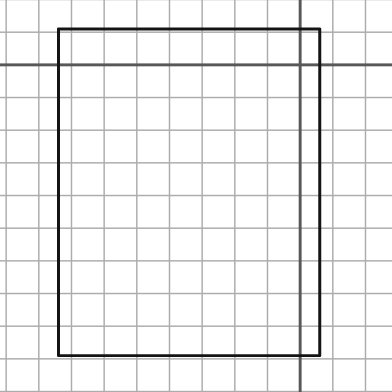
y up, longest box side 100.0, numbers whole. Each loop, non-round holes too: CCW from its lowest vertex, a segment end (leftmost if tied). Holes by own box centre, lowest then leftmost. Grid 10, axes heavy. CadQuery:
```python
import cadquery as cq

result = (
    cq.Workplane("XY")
    .moveTo(-74.0, -89.0)
    .lineTo(6.0, -89.0)
    .lineTo(6.0, 11.0)
    .lineTo(-74.0, 11.0)
    .close()
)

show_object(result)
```